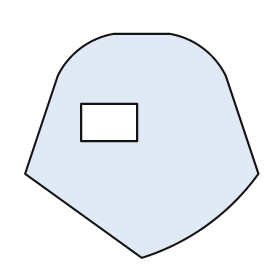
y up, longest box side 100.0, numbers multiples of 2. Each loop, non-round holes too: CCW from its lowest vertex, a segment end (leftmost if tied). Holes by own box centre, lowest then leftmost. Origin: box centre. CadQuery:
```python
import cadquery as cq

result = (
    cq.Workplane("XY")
    .moveTo(0.0, -48.0)
    .threePointArc((28.0, -34.0), (50.0, -12.0))
    .lineTo(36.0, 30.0)
    .threePointArc((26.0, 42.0), (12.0, 48.0))
    .lineTo(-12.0, 48.0)
    .threePointArc((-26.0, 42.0), (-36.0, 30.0))
    .lineTo(-50.0, -12.0)
    .close()
    .moveTo(-26.0, 2.0)
    .lineTo(-2.0, 2.0)
    .lineTo(-2.0, 18.0)
    .lineTo(-26.0, 18.0)
    .close()
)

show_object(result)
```